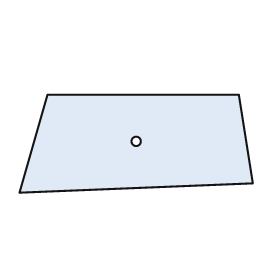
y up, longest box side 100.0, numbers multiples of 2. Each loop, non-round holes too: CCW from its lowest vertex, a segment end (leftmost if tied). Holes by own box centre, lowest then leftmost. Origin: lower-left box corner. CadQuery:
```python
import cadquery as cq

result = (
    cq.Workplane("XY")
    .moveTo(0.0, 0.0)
    .lineTo(100.0, 4.0)
    .lineTo(94.0, 42.0)
    .lineTo(12.0, 42.0)
    .close()
    .moveTo(50.0, 22.0)
    .circle(2.0)
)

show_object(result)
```